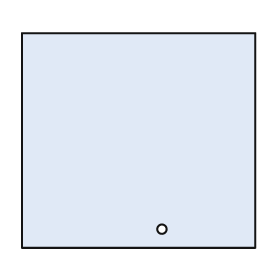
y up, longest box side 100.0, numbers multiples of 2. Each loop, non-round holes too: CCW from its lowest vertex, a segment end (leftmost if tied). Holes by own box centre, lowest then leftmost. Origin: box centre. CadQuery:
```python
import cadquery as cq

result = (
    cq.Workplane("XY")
    .moveTo(-50.0, -46.0)
    .lineTo(50.0, -46.0)
    .lineTo(50.0, 46.0)
    .lineTo(-50.0, 46.0)
    .close()
    .moveTo(10.0, -38.0)
    .circle(2.0)
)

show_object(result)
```